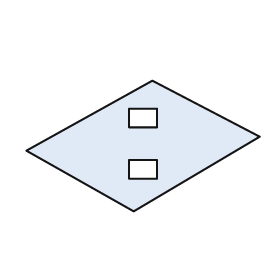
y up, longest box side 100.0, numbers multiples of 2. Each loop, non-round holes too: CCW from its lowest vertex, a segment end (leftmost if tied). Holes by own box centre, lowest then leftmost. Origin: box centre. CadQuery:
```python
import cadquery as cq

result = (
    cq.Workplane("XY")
    .moveTo(-4.0, -28.0)
    .lineTo(50.0, 4.0)
    .lineTo(4.0, 28.0)
    .lineTo(-50.0, -2.0)
    .close()
    .moveTo(-6.0, -14.0)
    .lineTo(6.0, -14.0)
    .lineTo(6.0, -6.0)
    .lineTo(-6.0, -6.0)
    .close()
    .moveTo(-6.0, 8.0)
    .lineTo(6.0, 8.0)
    .lineTo(6.0, 16.0)
    .lineTo(-6.0, 16.0)
    .close()
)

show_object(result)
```